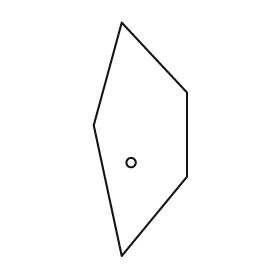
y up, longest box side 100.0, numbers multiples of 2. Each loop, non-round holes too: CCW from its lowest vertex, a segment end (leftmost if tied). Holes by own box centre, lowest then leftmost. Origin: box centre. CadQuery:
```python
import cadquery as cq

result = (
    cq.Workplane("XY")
    .moveTo(-8.0, -50.0)
    .lineTo(20.0, -16.0)
    .lineTo(20.0, 20.0)
    .lineTo(-8.0, 50.0)
    .lineTo(-20.0, 6.0)
    .close()
    .moveTo(-4.0, -10.0)
    .circle(2.0)
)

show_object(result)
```